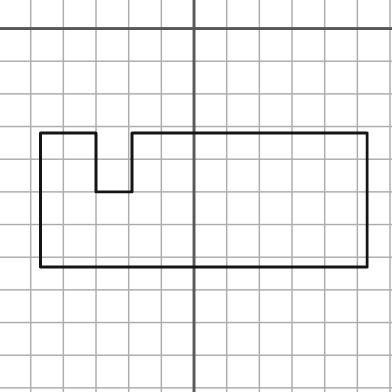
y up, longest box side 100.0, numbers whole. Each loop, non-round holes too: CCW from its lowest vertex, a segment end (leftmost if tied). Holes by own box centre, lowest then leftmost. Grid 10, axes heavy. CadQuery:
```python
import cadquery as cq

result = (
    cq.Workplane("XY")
    .moveTo(-47.0, -73.0)
    .lineTo(53.0, -73.0)
    .lineTo(53.0, -32.0)
    .lineTo(-19.0, -32.0)
    .lineTo(-19.0, -50.0)
    .lineTo(-30.0, -50.0)
    .lineTo(-30.0, -32.0)
    .lineTo(-47.0, -32.0)
    .close()
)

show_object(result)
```